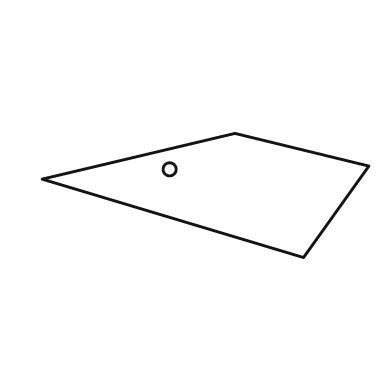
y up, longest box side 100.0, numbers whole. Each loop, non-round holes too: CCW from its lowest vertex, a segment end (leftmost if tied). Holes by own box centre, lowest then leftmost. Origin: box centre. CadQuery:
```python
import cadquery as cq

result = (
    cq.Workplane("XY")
    .moveTo(30.0, -19.0)
    .lineTo(50.0, 9.0)
    .lineTo(9.0, 19.0)
    .lineTo(-50.0, 5.0)
    .close()
    .moveTo(-11.0, 8.0)
    .circle(2.0)
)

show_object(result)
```